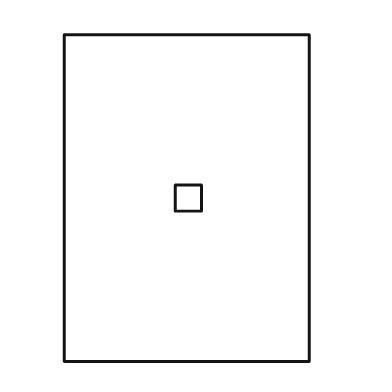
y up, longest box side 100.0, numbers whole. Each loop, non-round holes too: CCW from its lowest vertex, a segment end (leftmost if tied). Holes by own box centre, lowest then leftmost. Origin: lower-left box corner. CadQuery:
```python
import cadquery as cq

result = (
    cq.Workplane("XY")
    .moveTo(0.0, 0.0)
    .lineTo(75.0, 0.0)
    .lineTo(75.0, 100.0)
    .lineTo(0.0, 100.0)
    .close()
    .moveTo(34.0, 46.0)
    .lineTo(42.0, 46.0)
    .lineTo(42.0, 54.0)
    .lineTo(34.0, 54.0)
    .close()
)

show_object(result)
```